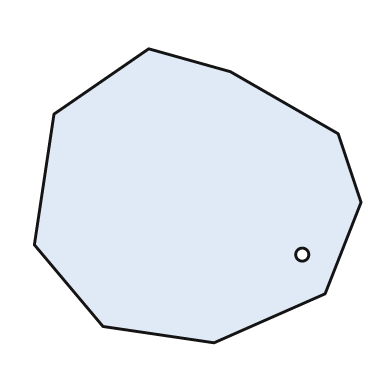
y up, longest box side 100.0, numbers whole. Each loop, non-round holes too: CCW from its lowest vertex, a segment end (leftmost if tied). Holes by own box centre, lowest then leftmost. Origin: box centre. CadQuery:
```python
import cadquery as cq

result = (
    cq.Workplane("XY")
    .moveTo(5.0, -45.0)
    .lineTo(39.0, -30.0)
    .lineTo(50.0, -2.0)
    .lineTo(43.0, 19.0)
    .lineTo(10.0, 38.0)
    .lineTo(-15.0, 45.0)
    .lineTo(-44.0, 25.0)
    .lineTo(-50.0, -15.0)
    .lineTo(-29.0, -40.0)
    .close()
    .moveTo(32.0, -18.0)
    .circle(2.0)
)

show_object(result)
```